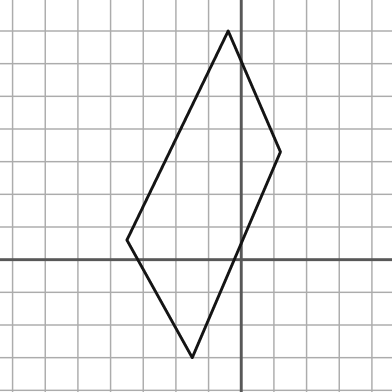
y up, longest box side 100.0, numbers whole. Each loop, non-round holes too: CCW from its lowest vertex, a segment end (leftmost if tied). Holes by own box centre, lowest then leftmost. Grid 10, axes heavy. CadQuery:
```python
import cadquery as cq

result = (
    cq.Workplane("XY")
    .moveTo(-15.0, -30.0)
    .lineTo(12.0, 33.0)
    .lineTo(-4.0, 70.0)
    .lineTo(-35.0, 6.0)
    .close()
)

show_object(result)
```